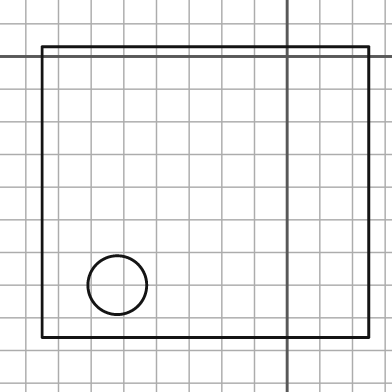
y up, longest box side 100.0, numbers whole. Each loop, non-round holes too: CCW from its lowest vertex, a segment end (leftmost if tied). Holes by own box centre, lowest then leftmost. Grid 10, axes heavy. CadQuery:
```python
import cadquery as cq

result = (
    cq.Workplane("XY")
    .moveTo(-75.0, -86.0)
    .lineTo(25.0, -86.0)
    .lineTo(25.0, 3.0)
    .lineTo(-75.0, 3.0)
    .close()
    .moveTo(-52.0, -70.0)
    .circle(9.0)
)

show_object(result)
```